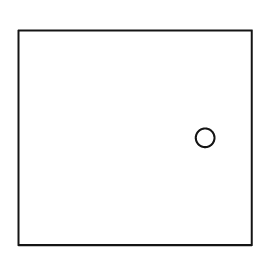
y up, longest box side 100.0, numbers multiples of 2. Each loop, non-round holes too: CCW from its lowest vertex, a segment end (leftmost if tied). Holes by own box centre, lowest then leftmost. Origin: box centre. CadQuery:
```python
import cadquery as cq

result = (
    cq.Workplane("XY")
    .moveTo(-50.0, -46.0)
    .lineTo(50.0, -46.0)
    .lineTo(50.0, 46.0)
    .lineTo(-50.0, 46.0)
    .close()
    .moveTo(30.0, 0.0)
    .circle(4.0)
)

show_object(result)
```